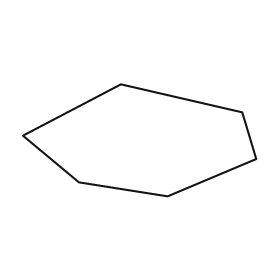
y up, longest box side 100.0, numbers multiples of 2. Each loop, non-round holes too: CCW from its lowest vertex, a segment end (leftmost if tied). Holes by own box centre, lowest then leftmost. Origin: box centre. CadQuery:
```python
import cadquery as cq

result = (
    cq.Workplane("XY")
    .moveTo(12.0, -24.0)
    .lineTo(50.0, -8.0)
    .lineTo(44.0, 12.0)
    .lineTo(-8.0, 24.0)
    .lineTo(-50.0, 2.0)
    .lineTo(-26.0, -18.0)
    .close()
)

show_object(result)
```